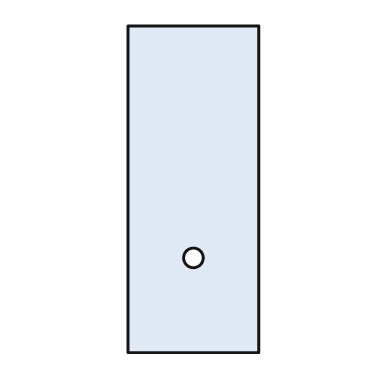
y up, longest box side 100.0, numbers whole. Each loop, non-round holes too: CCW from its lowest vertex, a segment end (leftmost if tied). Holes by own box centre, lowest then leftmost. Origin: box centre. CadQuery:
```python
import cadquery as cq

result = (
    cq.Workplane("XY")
    .moveTo(-20.0, -50.0)
    .lineTo(20.0, -50.0)
    .lineTo(20.0, 50.0)
    .lineTo(-20.0, 50.0)
    .close()
    .moveTo(0.0, -21.0)
    .circle(3.0)
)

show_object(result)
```